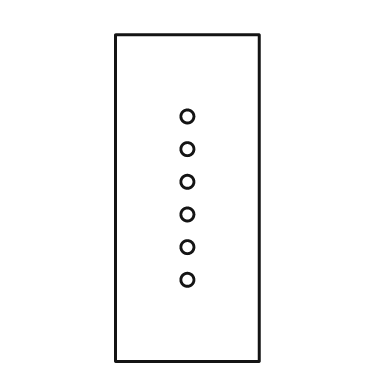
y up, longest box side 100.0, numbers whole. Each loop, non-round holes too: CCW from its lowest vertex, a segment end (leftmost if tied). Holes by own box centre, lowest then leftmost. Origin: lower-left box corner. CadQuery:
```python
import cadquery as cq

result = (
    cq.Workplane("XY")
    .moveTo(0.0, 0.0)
    .lineTo(44.0, 0.0)
    .lineTo(44.0, 100.0)
    .lineTo(0.0, 100.0)
    .close()
    .moveTo(22.0, 25.0)
    .circle(2.0)
    .moveTo(22.0, 35.0)
    .circle(2.0)
    .moveTo(22.0, 45.0)
    .circle(2.0)
    .moveTo(22.0, 55.0)
    .circle(2.0)
    .moveTo(22.0, 65.0)
    .circle(2.0)
    .moveTo(22.0, 75.0)
    .circle(2.0)
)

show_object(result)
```